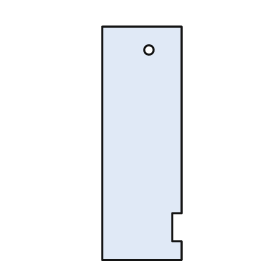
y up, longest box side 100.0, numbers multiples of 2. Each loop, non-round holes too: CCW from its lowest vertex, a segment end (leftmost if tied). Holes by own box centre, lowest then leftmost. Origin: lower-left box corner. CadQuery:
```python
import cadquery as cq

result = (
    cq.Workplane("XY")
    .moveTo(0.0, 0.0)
    .lineTo(34.0, 0.0)
    .lineTo(34.0, 8.0)
    .lineTo(30.0, 8.0)
    .lineTo(30.0, 20.0)
    .lineTo(34.0, 20.0)
    .lineTo(34.0, 100.0)
    .lineTo(0.0, 100.0)
    .close()
    .moveTo(20.0, 90.0)
    .circle(2.0)
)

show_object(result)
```